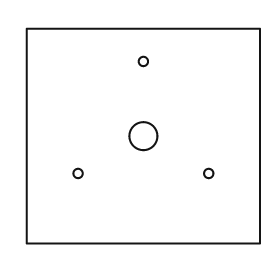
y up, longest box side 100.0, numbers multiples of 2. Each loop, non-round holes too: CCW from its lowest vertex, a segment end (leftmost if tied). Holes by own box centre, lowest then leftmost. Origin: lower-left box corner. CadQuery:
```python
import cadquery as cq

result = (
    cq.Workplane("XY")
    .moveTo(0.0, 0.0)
    .lineTo(100.0, 0.0)
    .lineTo(100.0, 92.0)
    .lineTo(0.0, 92.0)
    .close()
    .moveTo(22.0, 30.0)
    .circle(2.0)
    .moveTo(78.0, 30.0)
    .circle(2.0)
    .moveTo(50.0, 46.0)
    .circle(6.0)
    .moveTo(50.0, 78.0)
    .circle(2.0)
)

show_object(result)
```